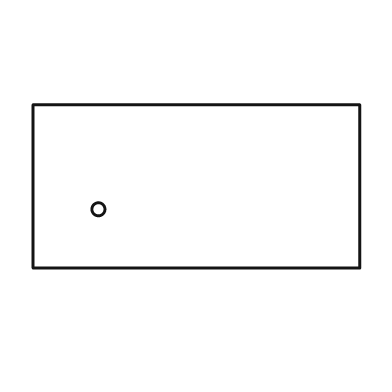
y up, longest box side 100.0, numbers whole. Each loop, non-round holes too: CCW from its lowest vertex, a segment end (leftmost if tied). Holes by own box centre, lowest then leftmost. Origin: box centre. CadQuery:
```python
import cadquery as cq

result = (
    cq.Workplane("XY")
    .moveTo(-50.0, -25.0)
    .lineTo(50.0, -25.0)
    .lineTo(50.0, 25.0)
    .lineTo(-50.0, 25.0)
    .close()
    .moveTo(-30.0, -7.0)
    .circle(2.0)
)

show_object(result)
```